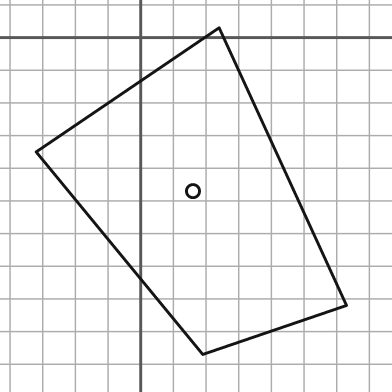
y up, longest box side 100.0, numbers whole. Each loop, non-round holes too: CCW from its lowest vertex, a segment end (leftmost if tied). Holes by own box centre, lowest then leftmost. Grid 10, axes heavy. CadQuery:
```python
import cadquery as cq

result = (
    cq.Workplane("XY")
    .moveTo(19.0, -97.0)
    .lineTo(63.0, -82.0)
    .lineTo(24.0, 3.0)
    .lineTo(-32.0, -35.0)
    .close()
    .moveTo(16.0, -47.0)
    .circle(2.0)
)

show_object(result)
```